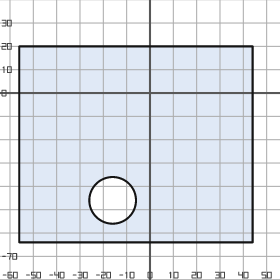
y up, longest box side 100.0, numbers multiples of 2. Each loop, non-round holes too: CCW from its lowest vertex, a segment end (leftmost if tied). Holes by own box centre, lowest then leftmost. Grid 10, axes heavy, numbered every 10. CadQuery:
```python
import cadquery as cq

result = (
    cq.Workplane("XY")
    .moveTo(-56.0, -64.0)
    .lineTo(44.0, -64.0)
    .lineTo(44.0, 20.0)
    .lineTo(-56.0, 20.0)
    .close()
    .moveTo(-16.0, -46.0)
    .circle(10.0)
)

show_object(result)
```